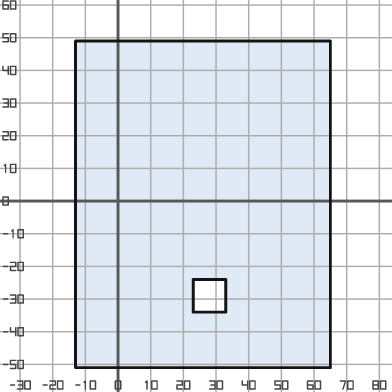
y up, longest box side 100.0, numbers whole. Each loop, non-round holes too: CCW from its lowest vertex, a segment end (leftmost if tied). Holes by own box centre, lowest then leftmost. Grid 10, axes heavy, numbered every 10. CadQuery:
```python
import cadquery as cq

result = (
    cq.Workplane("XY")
    .moveTo(-13.0, -51.0)
    .lineTo(65.0, -51.0)
    .lineTo(65.0, 49.0)
    .lineTo(-13.0, 49.0)
    .close()
    .moveTo(23.0, -34.0)
    .lineTo(33.0, -34.0)
    .lineTo(33.0, -24.0)
    .lineTo(23.0, -24.0)
    .close()
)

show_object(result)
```